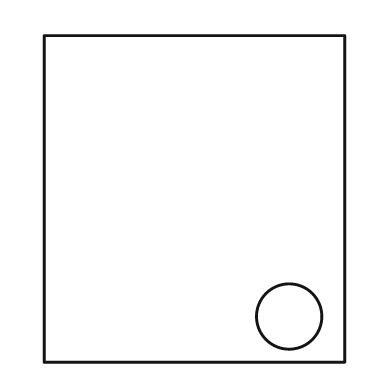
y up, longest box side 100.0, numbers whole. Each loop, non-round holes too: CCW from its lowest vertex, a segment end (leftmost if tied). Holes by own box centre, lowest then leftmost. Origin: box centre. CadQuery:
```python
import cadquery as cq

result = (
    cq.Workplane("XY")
    .moveTo(-46.0, -50.0)
    .lineTo(46.0, -50.0)
    .lineTo(46.0, 50.0)
    .lineTo(-46.0, 50.0)
    .close()
    .moveTo(29.0, -36.0)
    .circle(10.0)
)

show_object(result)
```